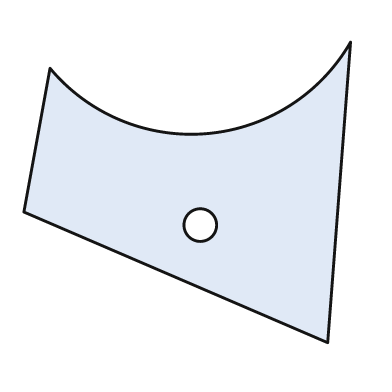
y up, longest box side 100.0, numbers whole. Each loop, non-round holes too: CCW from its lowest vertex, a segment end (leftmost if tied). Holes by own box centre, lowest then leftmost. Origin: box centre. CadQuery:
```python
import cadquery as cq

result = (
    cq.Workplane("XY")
    .moveTo(43.0, -46.0)
    .lineTo(50.0, 46.0)
    .threePointArc((6.0, 18.0), (-42.0, 38.0))
    .lineTo(-50.0, -6.0)
    .close()
    .moveTo(4.0, -10.0)
    .circle(5.0)
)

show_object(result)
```